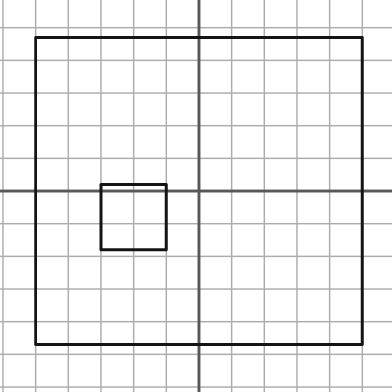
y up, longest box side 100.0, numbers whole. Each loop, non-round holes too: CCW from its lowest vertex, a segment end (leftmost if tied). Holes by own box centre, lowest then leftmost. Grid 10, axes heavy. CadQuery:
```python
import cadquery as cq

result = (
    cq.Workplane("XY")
    .moveTo(-50.0, -47.0)
    .lineTo(50.0, -47.0)
    .lineTo(50.0, 47.0)
    .lineTo(-50.0, 47.0)
    .close()
    .moveTo(-30.0, -18.0)
    .lineTo(-10.0, -18.0)
    .lineTo(-10.0, 2.0)
    .lineTo(-30.0, 2.0)
    .close()
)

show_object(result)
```